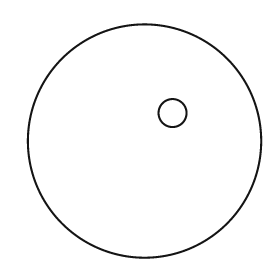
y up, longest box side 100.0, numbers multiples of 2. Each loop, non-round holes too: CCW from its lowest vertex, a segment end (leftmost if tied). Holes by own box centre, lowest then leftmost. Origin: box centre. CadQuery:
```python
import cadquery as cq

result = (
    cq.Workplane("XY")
    .moveTo(0.0, 0.0)
    .circle(50.0)
    .moveTo(12.0, 12.0)
    .circle(6.0)
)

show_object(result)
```